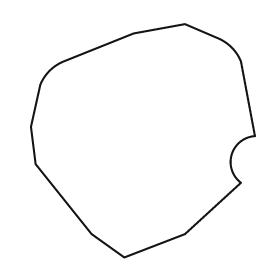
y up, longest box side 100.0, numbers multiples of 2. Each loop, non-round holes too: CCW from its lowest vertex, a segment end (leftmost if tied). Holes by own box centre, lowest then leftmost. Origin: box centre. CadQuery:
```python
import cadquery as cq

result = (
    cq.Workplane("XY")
    .moveTo(-8.0, -50.0)
    .lineTo(18.0, -40.0)
    .lineTo(42.0, -18.0)
    .threePointArc((38.0, -6.0), (48.0, 2.0))
    .lineTo(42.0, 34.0)
    .threePointArc((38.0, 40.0), (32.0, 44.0))
    .lineTo(18.0, 50.0)
    .lineTo(-4.0, 46.0)
    .lineTo(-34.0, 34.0)
    .threePointArc((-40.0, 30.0), (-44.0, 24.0))
    .lineTo(-48.0, 6.0)
    .lineTo(-46.0, -10.0)
    .lineTo(-22.0, -40.0)
    .close()
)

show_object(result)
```